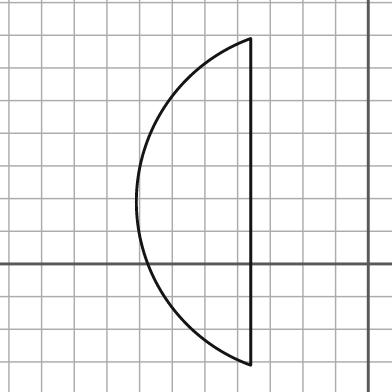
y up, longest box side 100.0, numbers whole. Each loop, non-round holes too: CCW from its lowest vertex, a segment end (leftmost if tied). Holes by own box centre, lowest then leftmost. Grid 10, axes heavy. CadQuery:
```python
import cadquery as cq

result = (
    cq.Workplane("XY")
    .moveTo(-36.0, -31.0)
    .lineTo(-36.0, 69.0)
    .threePointArc((-71.0, 19.0), (-36.0, -31.0))
    .close()
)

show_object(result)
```